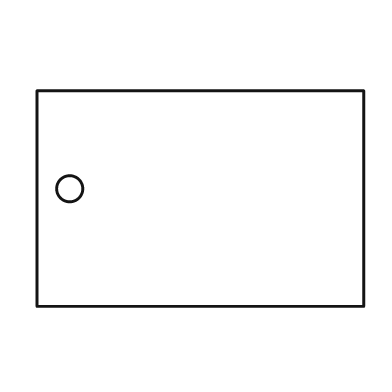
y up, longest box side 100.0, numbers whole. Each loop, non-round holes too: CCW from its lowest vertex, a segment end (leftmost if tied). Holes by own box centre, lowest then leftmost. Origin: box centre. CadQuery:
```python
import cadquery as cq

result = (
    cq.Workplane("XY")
    .moveTo(-50.0, -33.0)
    .lineTo(50.0, -33.0)
    .lineTo(50.0, 33.0)
    .lineTo(-50.0, 33.0)
    .close()
    .moveTo(-40.0, 3.0)
    .circle(4.0)
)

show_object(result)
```